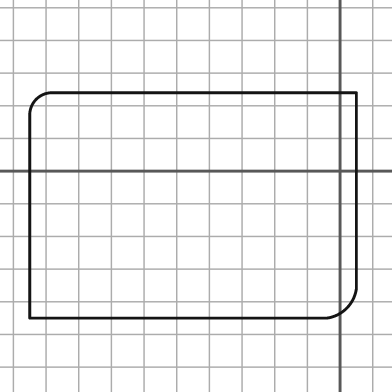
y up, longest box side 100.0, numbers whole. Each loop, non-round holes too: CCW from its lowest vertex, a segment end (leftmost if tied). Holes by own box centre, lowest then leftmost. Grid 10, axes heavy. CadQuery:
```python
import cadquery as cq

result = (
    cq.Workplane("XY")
    .moveTo(-95.0, -45.0)
    .lineTo(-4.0, -45.0)
    .threePointArc((2.0, -42.0), (5.0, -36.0))
    .lineTo(5.0, 24.0)
    .lineTo(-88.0, 24.0)
    .threePointArc((-93.0, 22.0), (-95.0, 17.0))
    .close()
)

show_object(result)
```